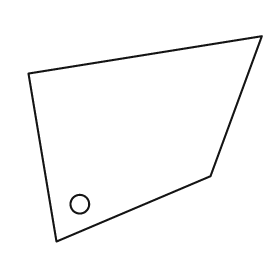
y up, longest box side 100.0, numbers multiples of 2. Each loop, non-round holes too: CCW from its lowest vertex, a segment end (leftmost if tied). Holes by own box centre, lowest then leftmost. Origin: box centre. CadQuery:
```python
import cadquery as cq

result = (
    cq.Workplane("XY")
    .moveTo(-38.0, -44.0)
    .lineTo(28.0, -16.0)
    .lineTo(50.0, 44.0)
    .lineTo(-50.0, 28.0)
    .close()
    .moveTo(-28.0, -28.0)
    .circle(4.0)
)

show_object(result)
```